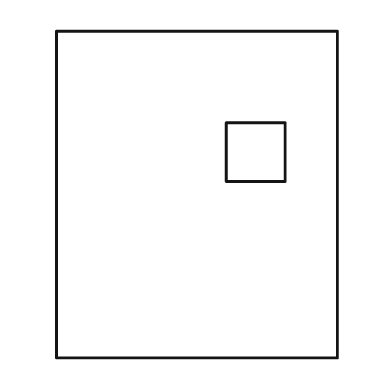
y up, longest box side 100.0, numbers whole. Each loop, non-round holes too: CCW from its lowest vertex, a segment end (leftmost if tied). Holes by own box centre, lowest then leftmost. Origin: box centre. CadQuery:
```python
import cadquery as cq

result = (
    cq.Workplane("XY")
    .moveTo(-43.0, -50.0)
    .lineTo(43.0, -50.0)
    .lineTo(43.0, 50.0)
    .lineTo(-43.0, 50.0)
    .close()
    .moveTo(9.0, 4.0)
    .lineTo(27.0, 4.0)
    .lineTo(27.0, 22.0)
    .lineTo(9.0, 22.0)
    .close()
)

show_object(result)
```